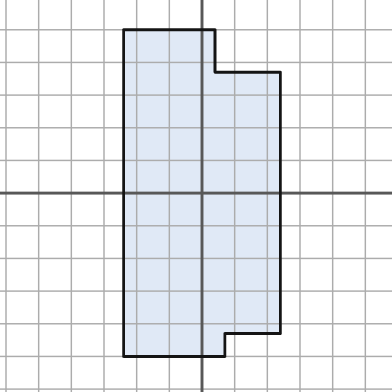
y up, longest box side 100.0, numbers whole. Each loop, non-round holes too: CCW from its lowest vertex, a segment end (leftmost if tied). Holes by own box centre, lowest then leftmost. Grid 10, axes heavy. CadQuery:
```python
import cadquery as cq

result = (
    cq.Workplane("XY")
    .moveTo(-24.0, -50.0)
    .lineTo(7.0, -50.0)
    .lineTo(7.0, -43.0)
    .lineTo(24.0, -43.0)
    .lineTo(24.0, 37.0)
    .lineTo(4.0, 37.0)
    .lineTo(4.0, 50.0)
    .lineTo(-24.0, 50.0)
    .close()
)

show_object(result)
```